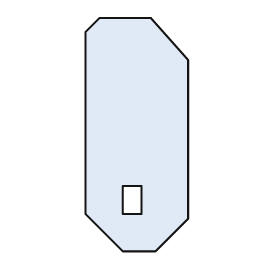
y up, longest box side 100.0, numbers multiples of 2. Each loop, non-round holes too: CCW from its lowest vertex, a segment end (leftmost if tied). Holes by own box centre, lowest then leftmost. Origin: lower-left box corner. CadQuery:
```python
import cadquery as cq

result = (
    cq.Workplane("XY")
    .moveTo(16.0, 0.0)
    .lineTo(30.0, 0.0)
    .lineTo(44.0, 14.0)
    .lineTo(44.0, 82.0)
    .lineTo(28.0, 100.0)
    .lineTo(6.0, 100.0)
    .lineTo(0.0, 94.0)
    .lineTo(0.0, 16.0)
    .close()
    .moveTo(16.0, 16.0)
    .lineTo(24.0, 16.0)
    .lineTo(24.0, 28.0)
    .lineTo(16.0, 28.0)
    .close()
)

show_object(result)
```